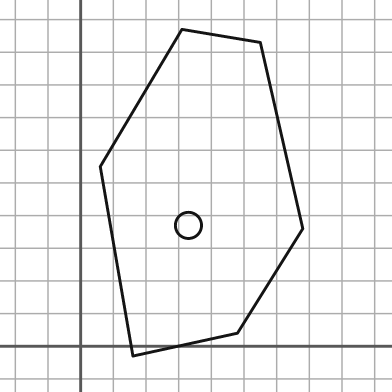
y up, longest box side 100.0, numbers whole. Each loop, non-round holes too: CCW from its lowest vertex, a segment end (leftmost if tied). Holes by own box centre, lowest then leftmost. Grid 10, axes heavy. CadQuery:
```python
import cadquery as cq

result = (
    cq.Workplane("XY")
    .moveTo(16.0, -3.0)
    .lineTo(48.0, 4.0)
    .lineTo(68.0, 36.0)
    .lineTo(55.0, 93.0)
    .lineTo(31.0, 97.0)
    .lineTo(6.0, 55.0)
    .close()
    .moveTo(33.0, 37.0)
    .circle(4.0)
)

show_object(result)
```